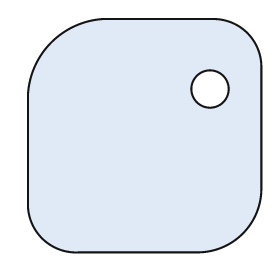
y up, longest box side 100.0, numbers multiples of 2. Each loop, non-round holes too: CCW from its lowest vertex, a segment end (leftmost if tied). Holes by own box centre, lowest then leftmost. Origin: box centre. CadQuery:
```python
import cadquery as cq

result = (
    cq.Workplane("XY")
    .moveTo(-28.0, -50.0)
    .lineTo(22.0, -50.0)
    .threePointArc((42.0, -42.0), (50.0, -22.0))
    .lineTo(50.0, 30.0)
    .threePointArc((44.0, 44.0), (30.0, 50.0))
    .lineTo(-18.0, 50.0)
    .threePointArc((-40.0, 40.0), (-50.0, 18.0))
    .lineTo(-50.0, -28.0)
    .threePointArc((-44.0, -44.0), (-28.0, -50.0))
    .close()
    .moveTo(28.0, 20.0)
    .circle(8.0)
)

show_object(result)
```